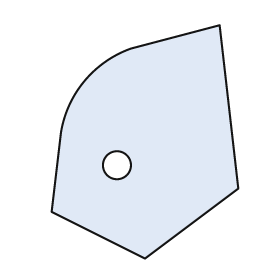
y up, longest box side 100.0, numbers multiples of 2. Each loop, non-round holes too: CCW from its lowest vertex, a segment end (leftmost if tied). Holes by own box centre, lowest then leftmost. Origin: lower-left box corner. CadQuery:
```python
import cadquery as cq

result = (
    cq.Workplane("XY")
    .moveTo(40.0, 0.0)
    .lineTo(80.0, 30.0)
    .lineTo(72.0, 100.0)
    .lineTo(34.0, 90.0)
    .threePointArc((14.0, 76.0), (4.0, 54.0))
    .lineTo(0.0, 20.0)
    .close()
    .moveTo(28.0, 40.0)
    .circle(6.0)
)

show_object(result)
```